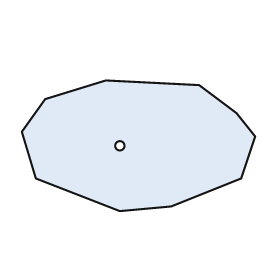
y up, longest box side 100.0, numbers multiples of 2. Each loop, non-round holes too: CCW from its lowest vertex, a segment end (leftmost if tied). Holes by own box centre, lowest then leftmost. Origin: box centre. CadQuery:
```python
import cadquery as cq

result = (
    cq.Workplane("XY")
    .moveTo(-8.0, -28.0)
    .lineTo(14.0, -26.0)
    .lineTo(44.0, -14.0)
    .lineTo(50.0, 4.0)
    .lineTo(42.0, 14.0)
    .lineTo(26.0, 26.0)
    .lineTo(-14.0, 28.0)
    .lineTo(-40.0, 20.0)
    .lineTo(-50.0, 6.0)
    .lineTo(-44.0, -14.0)
    .close()
    .moveTo(-8.0, 0.0)
    .circle(2.0)
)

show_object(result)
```